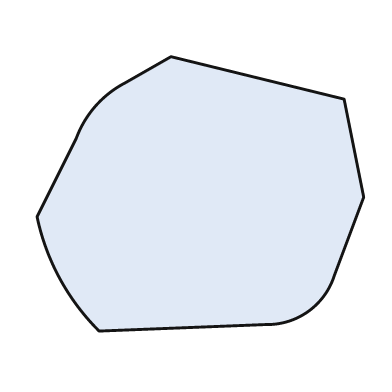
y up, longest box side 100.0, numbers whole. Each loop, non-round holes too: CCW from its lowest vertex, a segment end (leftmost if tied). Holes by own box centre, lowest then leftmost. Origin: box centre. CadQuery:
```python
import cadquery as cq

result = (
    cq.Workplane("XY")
    .moveTo(-31.0, -42.0)
    .lineTo(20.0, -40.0)
    .threePointArc((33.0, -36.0), (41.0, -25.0))
    .lineTo(50.0, -1.0)
    .lineTo(44.0, 29.0)
    .lineTo(-9.0, 42.0)
    .lineTo(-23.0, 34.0)
    .threePointArc((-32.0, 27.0), (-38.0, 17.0))
    .lineTo(-50.0, -7.0)
    .threePointArc((-43.0, -26.0), (-31.0, -42.0))
    .close()
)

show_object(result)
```